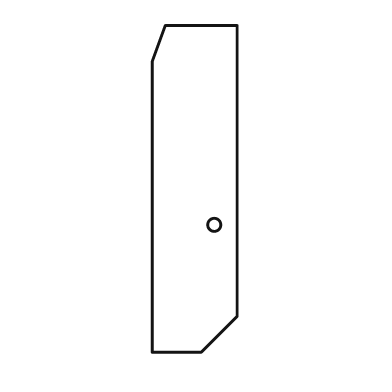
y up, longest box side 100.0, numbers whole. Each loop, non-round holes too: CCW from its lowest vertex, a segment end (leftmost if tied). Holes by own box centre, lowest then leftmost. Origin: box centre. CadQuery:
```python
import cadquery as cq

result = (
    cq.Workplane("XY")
    .moveTo(-13.0, -50.0)
    .lineTo(2.0, -50.0)
    .lineTo(13.0, -39.0)
    .lineTo(13.0, 50.0)
    .lineTo(-9.0, 50.0)
    .lineTo(-13.0, 39.0)
    .close()
    .moveTo(6.0, -11.0)
    .circle(2.0)
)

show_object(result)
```